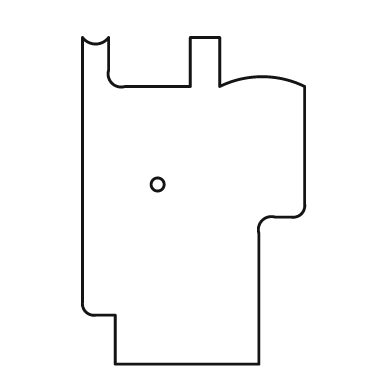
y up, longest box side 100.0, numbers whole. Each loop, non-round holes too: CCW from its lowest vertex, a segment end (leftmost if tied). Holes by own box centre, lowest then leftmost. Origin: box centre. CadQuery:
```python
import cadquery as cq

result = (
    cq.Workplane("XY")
    .moveTo(-24.0, -50.0)
    .lineTo(20.0, -50.0)
    .lineTo(20.0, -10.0)
    .threePointArc((21.0, -6.0), (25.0, -5.0))
    .lineTo(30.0, -5.0)
    .threePointArc((33.0, -4.0), (34.0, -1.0))
    .lineTo(34.0, 35.0)
    .threePointArc((21.0, 38.0), (8.0, 35.0))
    .lineTo(8.0, 50.0)
    .lineTo(-1.0, 50.0)
    .lineTo(-1.0, 35.0)
    .lineTo(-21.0, 35.0)
    .threePointArc((-25.0, 36.0), (-26.0, 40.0))
    .lineTo(-26.0, 50.0)
    .threePointArc((-30.0, 48.0), (-34.0, 50.0))
    .lineTo(-34.0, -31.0)
    .threePointArc((-33.0, -34.0), (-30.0, -35.0))
    .lineTo(-24.0, -35.0)
    .close()
    .moveTo(-11.0, 5.0)
    .circle(2.0)
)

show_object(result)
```